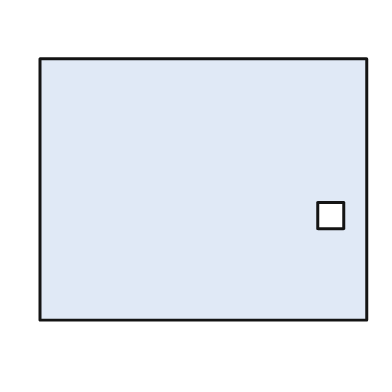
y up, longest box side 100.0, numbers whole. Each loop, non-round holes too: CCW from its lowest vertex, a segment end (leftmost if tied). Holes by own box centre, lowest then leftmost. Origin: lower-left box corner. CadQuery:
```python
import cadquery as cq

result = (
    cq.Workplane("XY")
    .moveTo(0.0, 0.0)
    .lineTo(100.0, 0.0)
    .lineTo(100.0, 80.0)
    .lineTo(0.0, 80.0)
    .close()
    .moveTo(85.0, 28.0)
    .lineTo(93.0, 28.0)
    .lineTo(93.0, 36.0)
    .lineTo(85.0, 36.0)
    .close()
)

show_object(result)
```